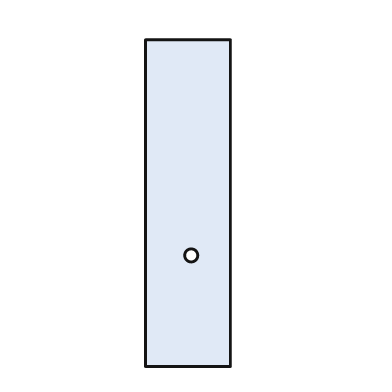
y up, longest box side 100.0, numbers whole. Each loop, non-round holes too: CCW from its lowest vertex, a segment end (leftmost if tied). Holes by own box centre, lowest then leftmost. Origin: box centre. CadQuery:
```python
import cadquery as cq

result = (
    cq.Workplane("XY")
    .moveTo(-13.0, -50.0)
    .lineTo(13.0, -50.0)
    .lineTo(13.0, 50.0)
    .lineTo(-13.0, 50.0)
    .close()
    .moveTo(1.0, -16.0)
    .circle(2.0)
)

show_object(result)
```